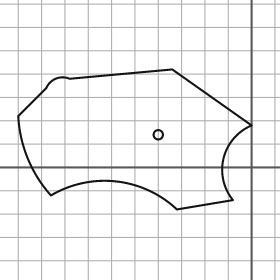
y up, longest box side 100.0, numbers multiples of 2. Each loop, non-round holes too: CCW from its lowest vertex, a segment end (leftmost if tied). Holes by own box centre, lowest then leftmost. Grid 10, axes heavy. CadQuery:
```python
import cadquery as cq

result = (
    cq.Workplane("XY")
    .moveTo(-32.0, -18.0)
    .lineTo(-8.0, -14.0)
    .threePointArc((-12.0, 4.0), (0.0, 18.0))
    .lineTo(-34.0, 42.0)
    .lineTo(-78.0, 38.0)
    .threePointArc((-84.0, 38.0), (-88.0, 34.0))
    .lineTo(-100.0, 22.0)
    .threePointArc((-96.0, 4.0), (-86.0, -12.0))
    .threePointArc((-58.0, -6.0), (-32.0, -18.0))
    .close()
    .moveTo(-40.0, 14.0)
    .circle(2.0)
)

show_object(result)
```